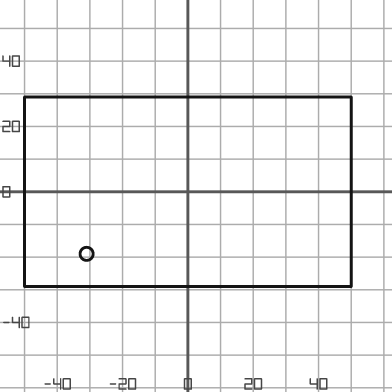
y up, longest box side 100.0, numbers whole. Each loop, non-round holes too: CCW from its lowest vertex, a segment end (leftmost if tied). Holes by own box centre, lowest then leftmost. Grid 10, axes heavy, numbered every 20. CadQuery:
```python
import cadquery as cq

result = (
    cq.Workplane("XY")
    .moveTo(-50.0, -29.0)
    .lineTo(50.0, -29.0)
    .lineTo(50.0, 29.0)
    .lineTo(-50.0, 29.0)
    .close()
    .moveTo(-31.0, -19.0)
    .circle(2.0)
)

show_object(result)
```